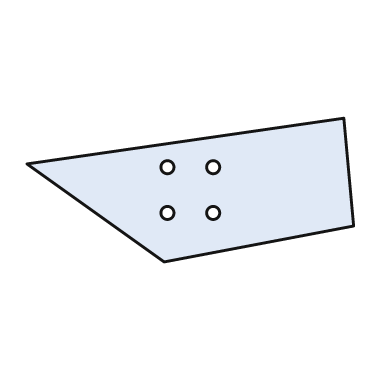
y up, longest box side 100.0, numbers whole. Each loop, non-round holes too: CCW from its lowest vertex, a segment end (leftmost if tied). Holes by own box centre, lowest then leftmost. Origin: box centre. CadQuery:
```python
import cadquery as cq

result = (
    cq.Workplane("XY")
    .moveTo(-8.0, -22.0)
    .lineTo(50.0, -11.0)
    .lineTo(47.0, 22.0)
    .lineTo(-50.0, 8.0)
    .close()
    .moveTo(-7.0, -7.0)
    .circle(2.0)
    .moveTo(7.0, -7.0)
    .circle(2.0)
    .moveTo(-7.0, 7.0)
    .circle(2.0)
    .moveTo(7.0, 7.0)
    .circle(2.0)
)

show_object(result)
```